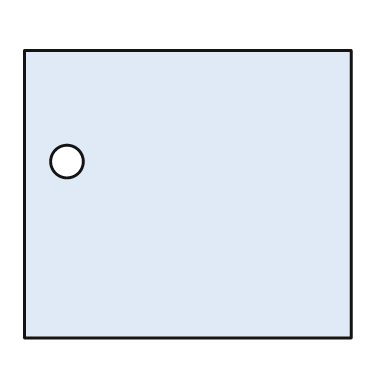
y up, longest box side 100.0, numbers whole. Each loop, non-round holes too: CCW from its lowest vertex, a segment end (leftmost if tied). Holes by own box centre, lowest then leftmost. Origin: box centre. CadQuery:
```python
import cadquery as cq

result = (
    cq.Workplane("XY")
    .moveTo(-50.0, -44.0)
    .lineTo(50.0, -44.0)
    .lineTo(50.0, 44.0)
    .lineTo(-50.0, 44.0)
    .close()
    .moveTo(-37.0, 10.0)
    .circle(5.0)
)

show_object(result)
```